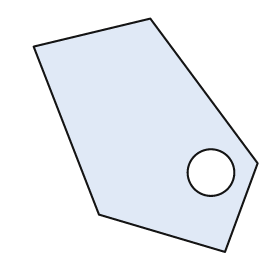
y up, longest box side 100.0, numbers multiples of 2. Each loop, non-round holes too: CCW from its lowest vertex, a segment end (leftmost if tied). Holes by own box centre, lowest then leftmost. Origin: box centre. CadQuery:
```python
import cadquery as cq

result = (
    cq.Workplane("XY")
    .moveTo(34.0, -50.0)
    .lineTo(48.0, -12.0)
    .lineTo(2.0, 50.0)
    .lineTo(-48.0, 38.0)
    .lineTo(-20.0, -34.0)
    .close()
    .moveTo(28.0, -16.0)
    .circle(10.0)
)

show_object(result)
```